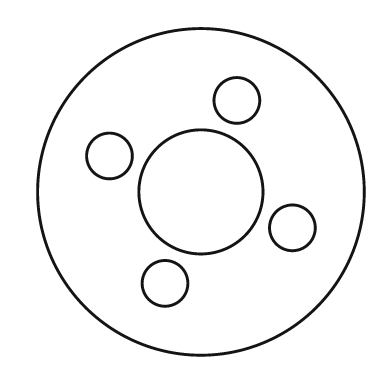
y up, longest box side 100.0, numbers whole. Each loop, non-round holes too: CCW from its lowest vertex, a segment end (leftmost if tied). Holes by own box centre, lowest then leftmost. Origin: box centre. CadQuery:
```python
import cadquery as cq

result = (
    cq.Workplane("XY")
    .moveTo(0.0, 0.0)
    .circle(50.0)
    .moveTo(-11.0, -28.0)
    .circle(7.0)
    .moveTo(28.0, -11.0)
    .circle(7.0)
    .moveTo(0.0, 0.0)
    .circle(19.0)
    .moveTo(-28.0, 11.0)
    .circle(7.0)
    .moveTo(11.0, 28.0)
    .circle(7.0)
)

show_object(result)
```